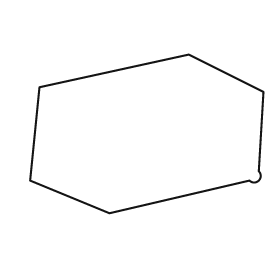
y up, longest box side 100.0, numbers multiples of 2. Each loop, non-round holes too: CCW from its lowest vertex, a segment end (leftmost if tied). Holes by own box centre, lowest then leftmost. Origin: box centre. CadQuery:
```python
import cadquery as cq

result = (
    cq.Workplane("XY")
    .moveTo(-16.0, -34.0)
    .lineTo(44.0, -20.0)
    .threePointArc((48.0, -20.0), (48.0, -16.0))
    .lineTo(50.0, 18.0)
    .lineTo(18.0, 34.0)
    .lineTo(-46.0, 20.0)
    .lineTo(-50.0, -20.0)
    .close()
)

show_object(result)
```